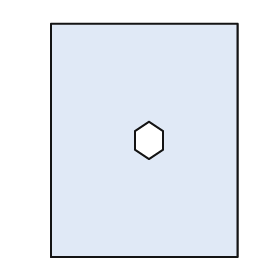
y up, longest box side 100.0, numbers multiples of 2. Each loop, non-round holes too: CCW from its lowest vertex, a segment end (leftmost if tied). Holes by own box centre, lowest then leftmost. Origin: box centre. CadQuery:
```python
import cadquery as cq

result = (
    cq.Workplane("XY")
    .moveTo(-40.0, -50.0)
    .lineTo(40.0, -50.0)
    .lineTo(40.0, 50.0)
    .lineTo(-40.0, 50.0)
    .close()
    .moveTo(2.0, -8.0)
    .lineTo(8.0, -4.0)
    .lineTo(8.0, 4.0)
    .lineTo(2.0, 8.0)
    .lineTo(-4.0, 4.0)
    .lineTo(-4.0, -4.0)
    .close()
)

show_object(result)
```